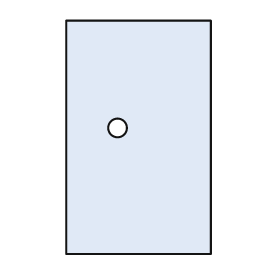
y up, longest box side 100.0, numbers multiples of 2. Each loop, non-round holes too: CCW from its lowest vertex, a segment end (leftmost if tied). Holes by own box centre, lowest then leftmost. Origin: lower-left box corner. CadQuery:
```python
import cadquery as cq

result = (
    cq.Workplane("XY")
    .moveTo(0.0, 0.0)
    .lineTo(62.0, 0.0)
    .lineTo(62.0, 100.0)
    .lineTo(0.0, 100.0)
    .close()
    .moveTo(22.0, 54.0)
    .circle(4.0)
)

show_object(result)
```